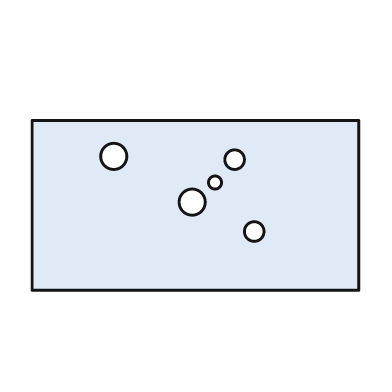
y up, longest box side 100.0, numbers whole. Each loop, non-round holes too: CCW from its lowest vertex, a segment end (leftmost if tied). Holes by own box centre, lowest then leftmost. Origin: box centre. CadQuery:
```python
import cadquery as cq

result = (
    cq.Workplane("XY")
    .moveTo(-50.0, -26.0)
    .lineTo(50.0, -26.0)
    .lineTo(50.0, 26.0)
    .lineTo(-50.0, 26.0)
    .close()
    .moveTo(18.0, -8.0)
    .circle(3.0)
    .moveTo(-1.0, 1.0)
    .circle(4.0)
    .moveTo(6.0, 7.0)
    .circle(2.0)
    .moveTo(12.0, 14.0)
    .circle(3.0)
    .moveTo(-25.0, 15.0)
    .circle(4.0)
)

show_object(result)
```